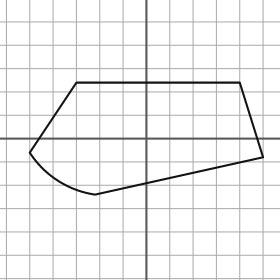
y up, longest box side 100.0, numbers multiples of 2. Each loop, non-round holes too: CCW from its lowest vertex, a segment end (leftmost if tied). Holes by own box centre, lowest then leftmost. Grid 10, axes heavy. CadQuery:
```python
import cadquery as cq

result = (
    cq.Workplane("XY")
    .moveTo(-22.0, -24.0)
    .lineTo(50.0, -8.0)
    .lineTo(40.0, 24.0)
    .lineTo(-30.0, 24.0)
    .lineTo(-50.0, -6.0)
    .threePointArc((-38.0, -18.0), (-22.0, -24.0))
    .close()
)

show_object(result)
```